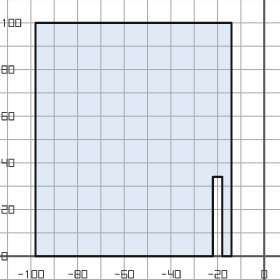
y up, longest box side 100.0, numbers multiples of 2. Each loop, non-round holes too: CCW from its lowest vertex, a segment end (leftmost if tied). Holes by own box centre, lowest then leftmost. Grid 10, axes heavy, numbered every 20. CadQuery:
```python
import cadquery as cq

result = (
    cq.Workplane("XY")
    .moveTo(-98.0, 0.0)
    .lineTo(-22.0, 0.0)
    .lineTo(-22.0, 34.0)
    .lineTo(-18.0, 34.0)
    .lineTo(-18.0, 0.0)
    .lineTo(-14.0, 0.0)
    .lineTo(-14.0, 100.0)
    .lineTo(-98.0, 100.0)
    .close()
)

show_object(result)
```